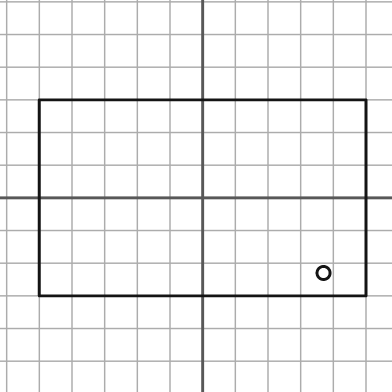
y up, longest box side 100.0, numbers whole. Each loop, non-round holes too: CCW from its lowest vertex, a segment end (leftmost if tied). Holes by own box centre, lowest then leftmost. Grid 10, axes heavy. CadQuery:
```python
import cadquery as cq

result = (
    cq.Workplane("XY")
    .moveTo(-50.0, -30.0)
    .lineTo(50.0, -30.0)
    .lineTo(50.0, 30.0)
    .lineTo(-50.0, 30.0)
    .close()
    .moveTo(37.0, -23.0)
    .circle(2.0)
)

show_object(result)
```